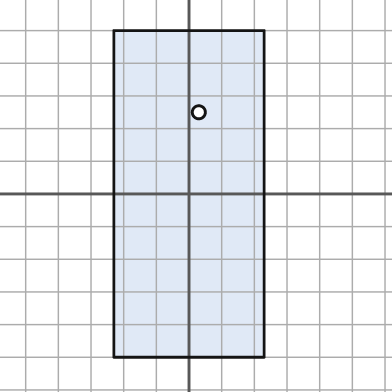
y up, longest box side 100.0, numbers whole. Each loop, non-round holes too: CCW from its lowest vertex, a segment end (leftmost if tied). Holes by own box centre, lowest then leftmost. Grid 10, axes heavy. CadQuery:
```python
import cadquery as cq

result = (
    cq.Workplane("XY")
    .moveTo(-23.0, -50.0)
    .lineTo(23.0, -50.0)
    .lineTo(23.0, 50.0)
    .lineTo(-23.0, 50.0)
    .close()
    .moveTo(3.0, 25.0)
    .circle(2.0)
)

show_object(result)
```